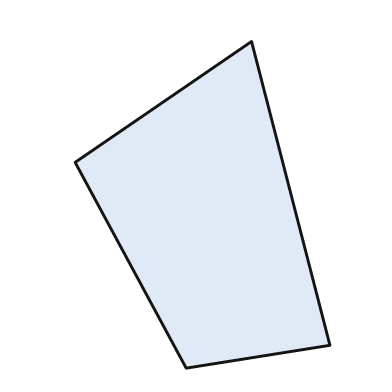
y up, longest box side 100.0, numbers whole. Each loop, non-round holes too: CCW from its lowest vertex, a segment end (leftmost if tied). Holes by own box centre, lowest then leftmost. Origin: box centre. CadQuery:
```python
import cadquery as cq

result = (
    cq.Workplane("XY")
    .moveTo(-5.0, -50.0)
    .lineTo(39.0, -43.0)
    .lineTo(15.0, 50.0)
    .lineTo(-39.0, 13.0)
    .close()
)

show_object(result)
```